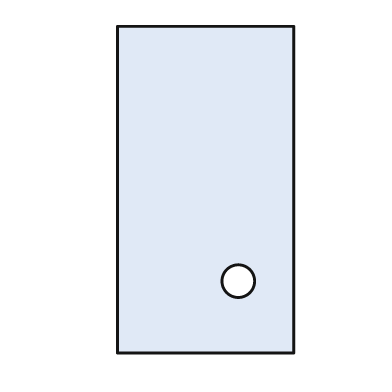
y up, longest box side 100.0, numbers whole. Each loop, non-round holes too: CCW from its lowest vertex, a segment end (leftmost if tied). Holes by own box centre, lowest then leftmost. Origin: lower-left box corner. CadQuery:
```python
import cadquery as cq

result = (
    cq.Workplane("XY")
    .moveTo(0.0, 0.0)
    .lineTo(54.0, 0.0)
    .lineTo(54.0, 100.0)
    .lineTo(0.0, 100.0)
    .close()
    .moveTo(37.0, 22.0)
    .circle(5.0)
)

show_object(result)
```